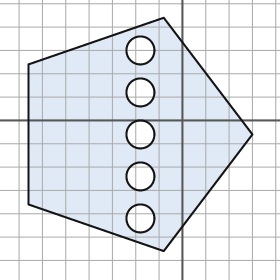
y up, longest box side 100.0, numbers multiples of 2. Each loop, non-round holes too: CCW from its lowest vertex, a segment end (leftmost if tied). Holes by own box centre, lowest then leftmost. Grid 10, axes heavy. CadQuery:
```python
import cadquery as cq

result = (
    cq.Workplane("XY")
    .moveTo(-8.0, -56.0)
    .lineTo(30.0, -6.0)
    .lineTo(-8.0, 44.0)
    .lineTo(-66.0, 24.0)
    .lineTo(-66.0, -36.0)
    .close()
    .moveTo(-18.0, -42.0)
    .circle(6.0)
    .moveTo(-18.0, -24.0)
    .circle(6.0)
    .moveTo(-18.0, -6.0)
    .circle(6.0)
    .moveTo(-18.0, 12.0)
    .circle(6.0)
    .moveTo(-18.0, 30.0)
    .circle(6.0)
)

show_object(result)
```